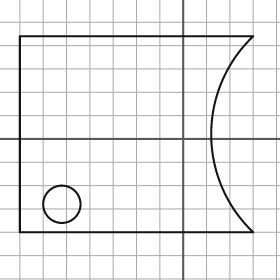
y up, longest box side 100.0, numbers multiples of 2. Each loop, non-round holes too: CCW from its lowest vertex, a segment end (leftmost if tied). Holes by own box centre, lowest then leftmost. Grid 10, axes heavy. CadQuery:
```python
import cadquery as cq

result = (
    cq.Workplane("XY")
    .moveTo(-70.0, -40.0)
    .lineTo(30.0, -40.0)
    .threePointArc((12.0, 2.0), (30.0, 44.0))
    .lineTo(-70.0, 44.0)
    .close()
    .moveTo(-52.0, -28.0)
    .circle(8.0)
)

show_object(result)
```